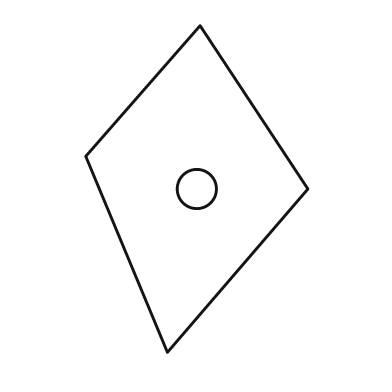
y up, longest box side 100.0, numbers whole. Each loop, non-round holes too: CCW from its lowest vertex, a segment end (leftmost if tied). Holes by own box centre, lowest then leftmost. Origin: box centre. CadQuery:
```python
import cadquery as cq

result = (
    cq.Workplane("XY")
    .moveTo(-9.0, -50.0)
    .lineTo(34.0, 0.0)
    .lineTo(1.0, 50.0)
    .lineTo(-34.0, 10.0)
    .close()
    .moveTo(0.0, 0.0)
    .circle(6.0)
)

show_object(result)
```